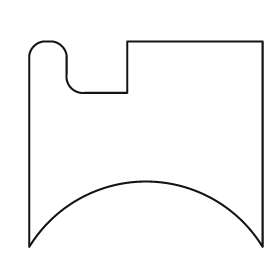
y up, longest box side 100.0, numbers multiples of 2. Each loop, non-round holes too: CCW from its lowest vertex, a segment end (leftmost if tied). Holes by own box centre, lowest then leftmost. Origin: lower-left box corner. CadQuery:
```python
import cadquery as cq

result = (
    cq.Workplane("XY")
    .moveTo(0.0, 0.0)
    .threePointArc((50.0, 28.0), (100.0, 0.0))
    .lineTo(100.0, 88.0)
    .lineTo(42.0, 88.0)
    .lineTo(42.0, 66.0)
    .lineTo(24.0, 66.0)
    .threePointArc((18.0, 68.0), (16.0, 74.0))
    .lineTo(16.0, 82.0)
    .threePointArc((14.0, 86.0), (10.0, 88.0))
    .lineTo(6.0, 88.0)
    .threePointArc((2.0, 86.0), (0.0, 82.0))
    .close()
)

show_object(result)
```